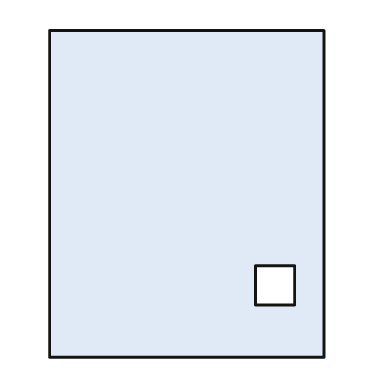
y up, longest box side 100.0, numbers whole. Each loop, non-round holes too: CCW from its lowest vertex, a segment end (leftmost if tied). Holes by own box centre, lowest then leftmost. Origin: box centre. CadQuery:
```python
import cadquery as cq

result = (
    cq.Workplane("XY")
    .moveTo(-42.0, -50.0)
    .lineTo(42.0, -50.0)
    .lineTo(42.0, 50.0)
    .lineTo(-42.0, 50.0)
    .close()
    .moveTo(21.0, -34.0)
    .lineTo(33.0, -34.0)
    .lineTo(33.0, -22.0)
    .lineTo(21.0, -22.0)
    .close()
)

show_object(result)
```